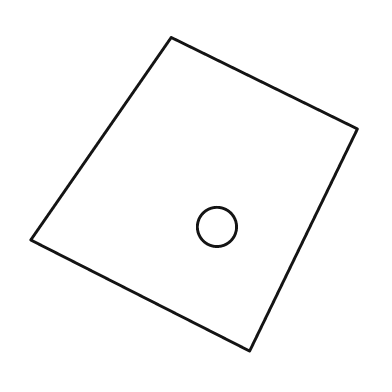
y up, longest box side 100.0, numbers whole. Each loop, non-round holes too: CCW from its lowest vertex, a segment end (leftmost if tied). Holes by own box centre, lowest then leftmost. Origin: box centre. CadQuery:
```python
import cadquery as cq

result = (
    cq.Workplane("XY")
    .moveTo(17.0, -48.0)
    .lineTo(50.0, 20.0)
    .lineTo(-7.0, 48.0)
    .lineTo(-50.0, -14.0)
    .close()
    .moveTo(7.0, -10.0)
    .circle(6.0)
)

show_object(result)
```